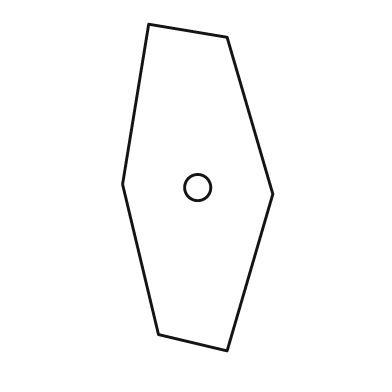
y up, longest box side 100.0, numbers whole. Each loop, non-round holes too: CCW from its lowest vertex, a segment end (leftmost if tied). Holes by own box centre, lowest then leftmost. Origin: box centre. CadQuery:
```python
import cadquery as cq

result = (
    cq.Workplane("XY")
    .moveTo(9.0, -50.0)
    .lineTo(23.0, -2.0)
    .lineTo(9.0, 46.0)
    .lineTo(-15.0, 50.0)
    .lineTo(-23.0, 1.0)
    .lineTo(-12.0, -45.0)
    .close()
    .moveTo(0.0, 0.0)
    .circle(4.0)
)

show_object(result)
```